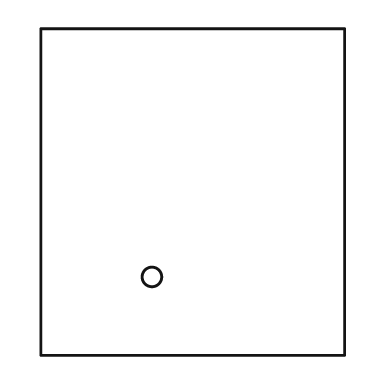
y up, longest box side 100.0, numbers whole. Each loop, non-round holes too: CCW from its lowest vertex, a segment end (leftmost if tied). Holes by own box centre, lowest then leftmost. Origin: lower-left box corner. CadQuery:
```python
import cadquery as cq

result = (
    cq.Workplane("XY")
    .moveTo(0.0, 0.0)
    .lineTo(93.0, 0.0)
    .lineTo(93.0, 100.0)
    .lineTo(0.0, 100.0)
    .close()
    .moveTo(34.0, 24.0)
    .circle(3.0)
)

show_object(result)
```